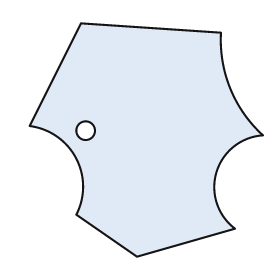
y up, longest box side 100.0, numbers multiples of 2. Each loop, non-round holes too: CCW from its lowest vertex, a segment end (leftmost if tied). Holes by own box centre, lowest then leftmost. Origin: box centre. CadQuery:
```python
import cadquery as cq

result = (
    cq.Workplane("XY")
    .moveTo(-4.0, -50.0)
    .lineTo(38.0, -38.0)
    .threePointArc((30.0, -14.0), (50.0, 2.0))
    .threePointArc((36.0, 22.0), (32.0, 46.0))
    .lineTo(-28.0, 50.0)
    .lineTo(-50.0, 6.0)
    .threePointArc((-30.0, -8.0), (-30.0, -32.0))
    .close()
    .moveTo(-26.0, 4.0)
    .circle(4.0)
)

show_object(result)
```